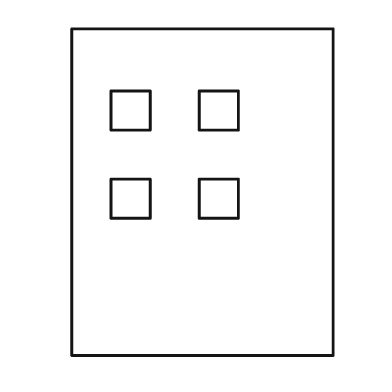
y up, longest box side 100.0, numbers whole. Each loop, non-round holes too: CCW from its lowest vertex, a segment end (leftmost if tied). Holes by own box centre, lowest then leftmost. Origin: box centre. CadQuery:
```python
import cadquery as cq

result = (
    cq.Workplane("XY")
    .moveTo(-40.0, -50.0)
    .lineTo(40.0, -50.0)
    .lineTo(40.0, 50.0)
    .lineTo(-40.0, 50.0)
    .close()
    .moveTo(-28.0, -8.0)
    .lineTo(-16.0, -8.0)
    .lineTo(-16.0, 4.0)
    .lineTo(-28.0, 4.0)
    .close()
    .moveTo(-1.0, -8.0)
    .lineTo(11.0, -8.0)
    .lineTo(11.0, 4.0)
    .lineTo(-1.0, 4.0)
    .close()
    .moveTo(-28.0, 19.0)
    .lineTo(-16.0, 19.0)
    .lineTo(-16.0, 31.0)
    .lineTo(-28.0, 31.0)
    .close()
    .moveTo(-1.0, 19.0)
    .lineTo(11.0, 19.0)
    .lineTo(11.0, 31.0)
    .lineTo(-1.0, 31.0)
    .close()
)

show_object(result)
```